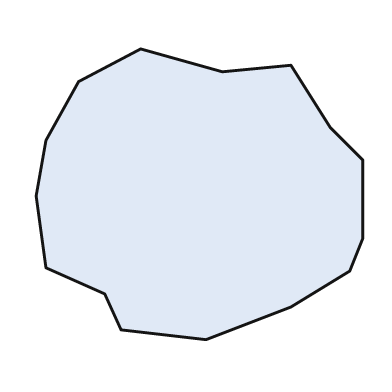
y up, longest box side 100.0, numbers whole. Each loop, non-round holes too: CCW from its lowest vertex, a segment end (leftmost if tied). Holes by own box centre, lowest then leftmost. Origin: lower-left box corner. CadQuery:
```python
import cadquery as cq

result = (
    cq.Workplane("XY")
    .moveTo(52.0, 0.0)
    .lineTo(78.0, 10.0)
    .lineTo(96.0, 21.0)
    .lineTo(100.0, 31.0)
    .lineTo(100.0, 55.0)
    .lineTo(90.0, 65.0)
    .lineTo(78.0, 84.0)
    .lineTo(57.0, 82.0)
    .lineTo(32.0, 89.0)
    .lineTo(13.0, 79.0)
    .lineTo(3.0, 61.0)
    .lineTo(0.0, 44.0)
    .lineTo(3.0, 22.0)
    .lineTo(21.0, 14.0)
    .lineTo(26.0, 3.0)
    .close()
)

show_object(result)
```